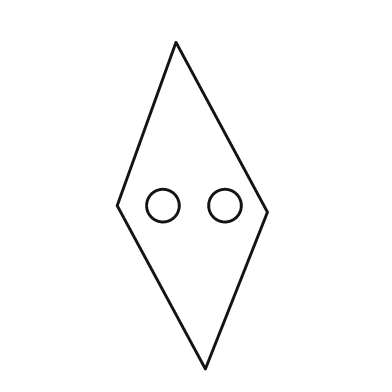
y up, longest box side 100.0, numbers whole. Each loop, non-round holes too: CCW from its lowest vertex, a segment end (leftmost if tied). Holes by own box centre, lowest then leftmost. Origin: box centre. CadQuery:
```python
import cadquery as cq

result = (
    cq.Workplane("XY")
    .moveTo(4.0, -50.0)
    .lineTo(23.0, -2.0)
    .lineTo(-5.0, 50.0)
    .lineTo(-23.0, 0.0)
    .close()
    .moveTo(-9.0, 0.0)
    .circle(5.0)
    .moveTo(10.0, 0.0)
    .circle(5.0)
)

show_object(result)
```